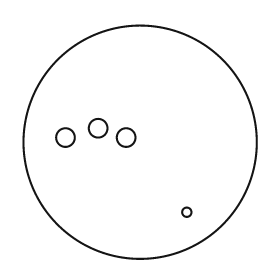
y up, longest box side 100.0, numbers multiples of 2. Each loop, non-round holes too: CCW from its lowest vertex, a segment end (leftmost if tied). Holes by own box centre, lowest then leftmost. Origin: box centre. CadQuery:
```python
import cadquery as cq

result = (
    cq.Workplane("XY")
    .moveTo(0.0, 0.0)
    .circle(50.0)
    .moveTo(20.0, -30.0)
    .circle(2.0)
    .moveTo(-32.0, 2.0)
    .circle(4.0)
    .moveTo(-6.0, 2.0)
    .circle(4.0)
    .moveTo(-18.0, 6.0)
    .circle(4.0)
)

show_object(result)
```